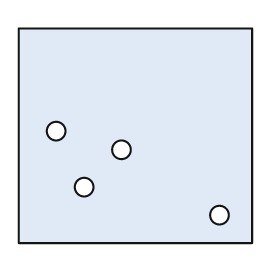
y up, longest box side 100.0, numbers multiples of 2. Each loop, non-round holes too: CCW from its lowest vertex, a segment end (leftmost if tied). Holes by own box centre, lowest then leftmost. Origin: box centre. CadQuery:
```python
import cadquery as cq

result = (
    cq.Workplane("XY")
    .moveTo(-50.0, -46.0)
    .lineTo(50.0, -46.0)
    .lineTo(50.0, 46.0)
    .lineTo(-50.0, 46.0)
    .close()
    .moveTo(36.0, -34.0)
    .circle(4.0)
    .moveTo(-22.0, -22.0)
    .circle(4.0)
    .moveTo(-6.0, -6.0)
    .circle(4.0)
    .moveTo(-34.0, 2.0)
    .circle(4.0)
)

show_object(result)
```